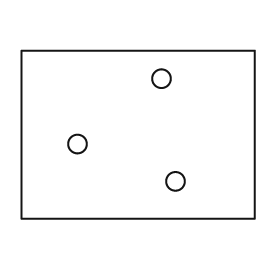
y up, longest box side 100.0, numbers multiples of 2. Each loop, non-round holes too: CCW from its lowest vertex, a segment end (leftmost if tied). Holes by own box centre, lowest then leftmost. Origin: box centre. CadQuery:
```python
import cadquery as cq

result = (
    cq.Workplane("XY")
    .moveTo(-50.0, -36.0)
    .lineTo(50.0, -36.0)
    .lineTo(50.0, 36.0)
    .lineTo(-50.0, 36.0)
    .close()
    .moveTo(16.0, -20.0)
    .circle(4.0)
    .moveTo(-26.0, -4.0)
    .circle(4.0)
    .moveTo(10.0, 24.0)
    .circle(4.0)
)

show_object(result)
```